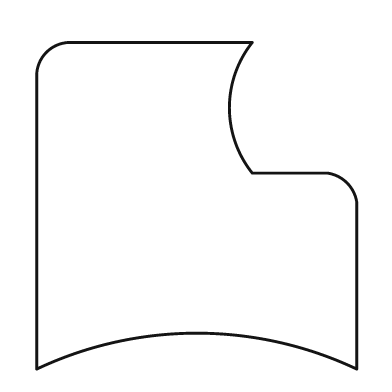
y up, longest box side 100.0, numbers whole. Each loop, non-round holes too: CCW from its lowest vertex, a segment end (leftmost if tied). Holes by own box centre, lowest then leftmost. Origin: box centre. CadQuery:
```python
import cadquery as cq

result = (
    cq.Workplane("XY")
    .moveTo(-49.0, -50.0)
    .threePointArc((0.0, -39.0), (49.0, -50.0))
    .lineTo(49.0, 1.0)
    .threePointArc((46.0, 7.0), (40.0, 10.0))
    .lineTo(17.0, 10.0)
    .threePointArc((10.0, 30.0), (17.0, 50.0))
    .lineTo(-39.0, 50.0)
    .threePointArc((-46.0, 47.0), (-49.0, 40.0))
    .close()
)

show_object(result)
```